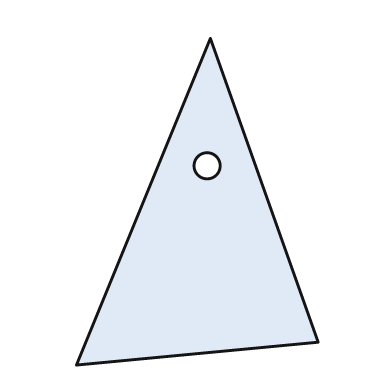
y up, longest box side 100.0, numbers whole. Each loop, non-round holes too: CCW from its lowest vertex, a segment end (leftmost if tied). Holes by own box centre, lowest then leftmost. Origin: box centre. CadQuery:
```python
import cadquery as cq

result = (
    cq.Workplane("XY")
    .moveTo(-37.0, -50.0)
    .lineTo(37.0, -43.0)
    .lineTo(4.0, 50.0)
    .close()
    .moveTo(3.0, 11.0)
    .circle(4.0)
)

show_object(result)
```